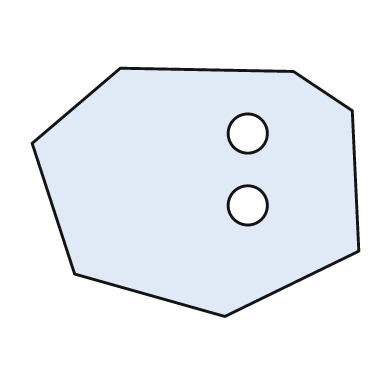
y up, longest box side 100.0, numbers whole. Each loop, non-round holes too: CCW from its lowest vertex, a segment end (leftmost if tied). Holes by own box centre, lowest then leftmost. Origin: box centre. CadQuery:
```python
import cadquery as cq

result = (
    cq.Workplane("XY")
    .moveTo(9.0, -38.0)
    .lineTo(50.0, -18.0)
    .lineTo(48.0, 25.0)
    .lineTo(30.0, 37.0)
    .lineTo(-23.0, 38.0)
    .lineTo(-50.0, 15.0)
    .lineTo(-37.0, -25.0)
    .close()
    .moveTo(16.0, -4.0)
    .circle(6.0)
    .moveTo(16.0, 18.0)
    .circle(6.0)
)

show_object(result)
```